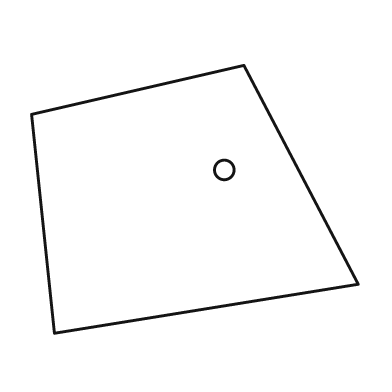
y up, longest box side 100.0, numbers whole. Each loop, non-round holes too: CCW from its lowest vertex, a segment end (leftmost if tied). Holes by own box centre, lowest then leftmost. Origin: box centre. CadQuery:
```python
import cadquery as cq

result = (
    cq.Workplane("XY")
    .moveTo(-43.0, -41.0)
    .lineTo(50.0, -26.0)
    .lineTo(15.0, 41.0)
    .lineTo(-50.0, 26.0)
    .close()
    .moveTo(9.0, 9.0)
    .circle(3.0)
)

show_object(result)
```